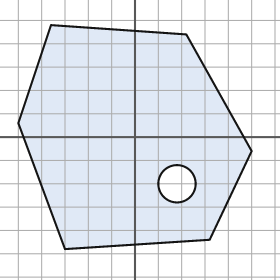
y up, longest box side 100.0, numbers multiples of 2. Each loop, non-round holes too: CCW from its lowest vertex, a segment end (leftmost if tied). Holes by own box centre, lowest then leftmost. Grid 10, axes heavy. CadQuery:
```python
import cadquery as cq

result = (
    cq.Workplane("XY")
    .moveTo(-30.0, -48.0)
    .lineTo(32.0, -44.0)
    .lineTo(50.0, -6.0)
    .lineTo(22.0, 44.0)
    .lineTo(-36.0, 48.0)
    .lineTo(-50.0, 6.0)
    .close()
    .moveTo(18.0, -20.0)
    .circle(8.0)
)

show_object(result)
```